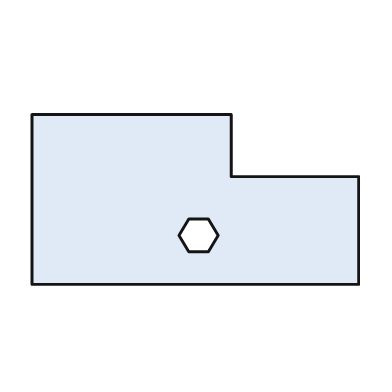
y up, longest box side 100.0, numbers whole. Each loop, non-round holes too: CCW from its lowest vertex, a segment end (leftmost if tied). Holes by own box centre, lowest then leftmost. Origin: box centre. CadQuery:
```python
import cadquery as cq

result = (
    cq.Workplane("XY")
    .moveTo(-50.0, -26.0)
    .lineTo(50.0, -26.0)
    .lineTo(50.0, 7.0)
    .lineTo(11.0, 7.0)
    .lineTo(11.0, 26.0)
    .lineTo(-50.0, 26.0)
    .close()
    .moveTo(-2.0, -16.0)
    .lineTo(4.0, -16.0)
    .lineTo(7.0, -11.0)
    .lineTo(4.0, -6.0)
    .lineTo(-2.0, -6.0)
    .lineTo(-5.0, -11.0)
    .close()
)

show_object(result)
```